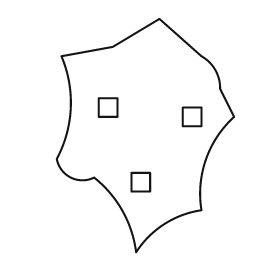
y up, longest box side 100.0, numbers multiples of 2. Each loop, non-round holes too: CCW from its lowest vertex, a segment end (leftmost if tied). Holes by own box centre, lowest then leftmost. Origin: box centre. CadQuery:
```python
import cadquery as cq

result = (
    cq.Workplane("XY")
    .moveTo(-4.0, -50.0)
    .threePointArc((8.0, -38.0), (24.0, -32.0))
    .threePointArc((26.0, -10.0), (38.0, 8.0))
    .lineTo(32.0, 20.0)
    .threePointArc((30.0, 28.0), (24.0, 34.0))
    .lineTo(6.0, 50.0)
    .lineTo(-14.0, 38.0)
    .lineTo(-36.0, 34.0)
    .threePointArc((-32.0, 12.0), (-38.0, -10.0))
    .threePointArc((-32.0, -18.0), (-22.0, -18.0))
    .threePointArc((-10.0, -32.0), (-4.0, -50.0))
    .close()
    .moveTo(-6.0, -24.0)
    .lineTo(2.0, -24.0)
    .lineTo(2.0, -16.0)
    .lineTo(-6.0, -16.0)
    .close()
    .moveTo(16.0, 4.0)
    .lineTo(24.0, 4.0)
    .lineTo(24.0, 12.0)
    .lineTo(16.0, 12.0)
    .close()
    .moveTo(-20.0, 8.0)
    .lineTo(-12.0, 8.0)
    .lineTo(-12.0, 16.0)
    .lineTo(-20.0, 16.0)
    .close()
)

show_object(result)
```